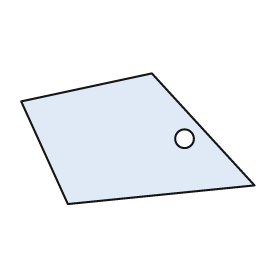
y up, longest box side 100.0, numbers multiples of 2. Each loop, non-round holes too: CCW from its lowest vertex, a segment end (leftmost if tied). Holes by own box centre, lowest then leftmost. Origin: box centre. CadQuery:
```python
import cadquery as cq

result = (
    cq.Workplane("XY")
    .moveTo(-30.0, -28.0)
    .lineTo(50.0, -20.0)
    .lineTo(6.0, 28.0)
    .lineTo(-50.0, 16.0)
    .close()
    .moveTo(20.0, 0.0)
    .circle(4.0)
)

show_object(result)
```